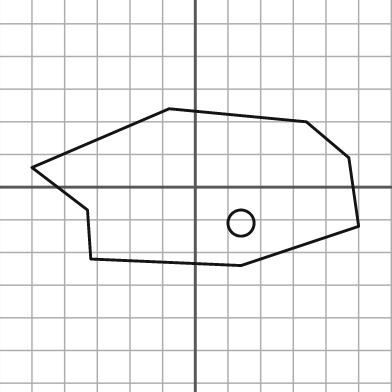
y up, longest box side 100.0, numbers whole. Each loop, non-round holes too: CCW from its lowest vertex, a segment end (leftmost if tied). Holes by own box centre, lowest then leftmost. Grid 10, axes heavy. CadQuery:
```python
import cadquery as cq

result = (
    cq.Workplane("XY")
    .moveTo(14.0, -24.0)
    .lineTo(50.0, -12.0)
    .lineTo(47.0, 9.0)
    .lineTo(34.0, 20.0)
    .lineTo(-8.0, 24.0)
    .lineTo(-50.0, 6.0)
    .lineTo(-33.0, -7.0)
    .lineTo(-32.0, -22.0)
    .close()
    .moveTo(14.0, -11.0)
    .circle(4.0)
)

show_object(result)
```